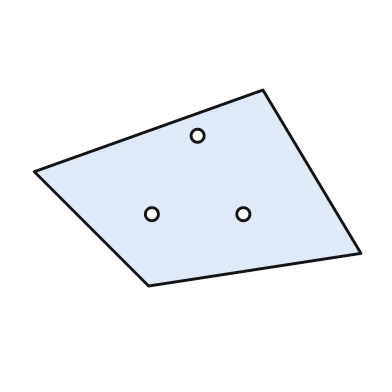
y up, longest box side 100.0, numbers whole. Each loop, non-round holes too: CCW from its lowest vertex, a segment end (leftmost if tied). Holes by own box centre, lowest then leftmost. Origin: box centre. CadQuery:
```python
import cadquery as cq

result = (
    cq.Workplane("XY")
    .moveTo(-15.0, -30.0)
    .lineTo(50.0, -20.0)
    .lineTo(20.0, 30.0)
    .lineTo(-50.0, 5.0)
    .close()
    .moveTo(-14.0, -8.0)
    .circle(2.0)
    .moveTo(14.0, -8.0)
    .circle(2.0)
    .moveTo(0.0, 16.0)
    .circle(2.0)
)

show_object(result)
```